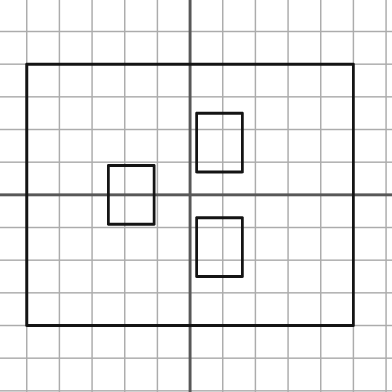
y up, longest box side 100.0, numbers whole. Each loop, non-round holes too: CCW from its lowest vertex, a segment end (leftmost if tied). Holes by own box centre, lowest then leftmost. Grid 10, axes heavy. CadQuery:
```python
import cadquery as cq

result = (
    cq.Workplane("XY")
    .moveTo(-50.0, -40.0)
    .lineTo(50.0, -40.0)
    .lineTo(50.0, 40.0)
    .lineTo(-50.0, 40.0)
    .close()
    .moveTo(2.0, -25.0)
    .lineTo(16.0, -25.0)
    .lineTo(16.0, -7.0)
    .lineTo(2.0, -7.0)
    .close()
    .moveTo(-25.0, -9.0)
    .lineTo(-11.0, -9.0)
    .lineTo(-11.0, 9.0)
    .lineTo(-25.0, 9.0)
    .close()
    .moveTo(2.0, 7.0)
    .lineTo(16.0, 7.0)
    .lineTo(16.0, 25.0)
    .lineTo(2.0, 25.0)
    .close()
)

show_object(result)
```